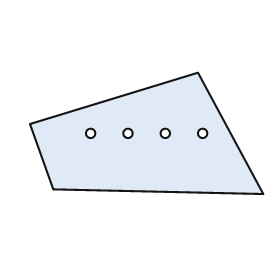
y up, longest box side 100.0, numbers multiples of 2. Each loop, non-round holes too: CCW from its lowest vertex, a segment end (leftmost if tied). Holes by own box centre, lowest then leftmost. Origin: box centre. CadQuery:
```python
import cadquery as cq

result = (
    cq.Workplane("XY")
    .moveTo(50.0, -26.0)
    .lineTo(22.0, 26.0)
    .lineTo(-50.0, 4.0)
    .lineTo(-40.0, -24.0)
    .close()
    .moveTo(-24.0, 0.0)
    .circle(2.0)
    .moveTo(-8.0, 0.0)
    .circle(2.0)
    .moveTo(8.0, 0.0)
    .circle(2.0)
    .moveTo(24.0, 0.0)
    .circle(2.0)
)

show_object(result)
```